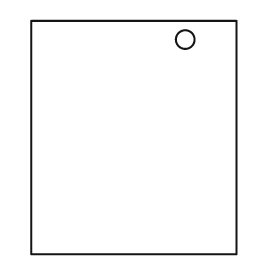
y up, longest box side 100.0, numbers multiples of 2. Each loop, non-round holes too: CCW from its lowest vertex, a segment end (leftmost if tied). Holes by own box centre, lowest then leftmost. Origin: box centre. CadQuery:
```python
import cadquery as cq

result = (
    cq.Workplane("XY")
    .moveTo(-44.0, -50.0)
    .lineTo(44.0, -50.0)
    .lineTo(44.0, 50.0)
    .lineTo(-44.0, 50.0)
    .close()
    .moveTo(22.0, 42.0)
    .circle(4.0)
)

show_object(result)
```